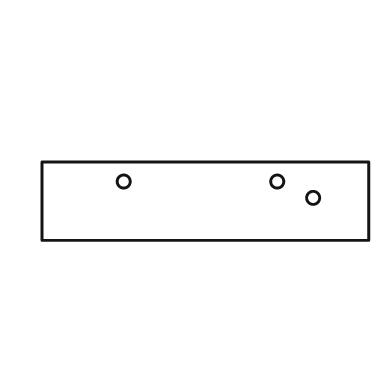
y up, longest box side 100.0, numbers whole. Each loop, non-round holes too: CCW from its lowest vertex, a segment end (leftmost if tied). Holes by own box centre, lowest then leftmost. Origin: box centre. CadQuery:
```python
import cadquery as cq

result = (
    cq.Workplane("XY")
    .moveTo(-50.0, -12.0)
    .lineTo(50.0, -12.0)
    .lineTo(50.0, 12.0)
    .lineTo(-50.0, 12.0)
    .close()
    .moveTo(33.0, 1.0)
    .circle(2.0)
    .moveTo(-25.0, 6.0)
    .circle(2.0)
    .moveTo(22.0, 6.0)
    .circle(2.0)
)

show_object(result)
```